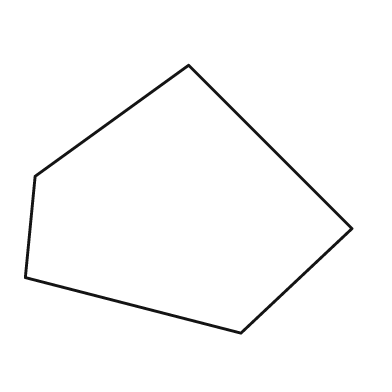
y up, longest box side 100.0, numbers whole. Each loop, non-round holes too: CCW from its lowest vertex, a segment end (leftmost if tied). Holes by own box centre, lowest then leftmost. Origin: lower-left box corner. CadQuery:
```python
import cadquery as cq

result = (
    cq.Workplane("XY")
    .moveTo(66.0, 0.0)
    .lineTo(100.0, 32.0)
    .lineTo(50.0, 82.0)
    .lineTo(3.0, 48.0)
    .lineTo(0.0, 17.0)
    .close()
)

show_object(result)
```